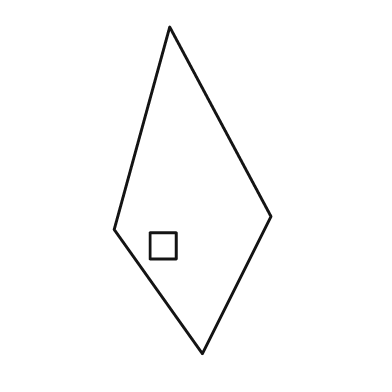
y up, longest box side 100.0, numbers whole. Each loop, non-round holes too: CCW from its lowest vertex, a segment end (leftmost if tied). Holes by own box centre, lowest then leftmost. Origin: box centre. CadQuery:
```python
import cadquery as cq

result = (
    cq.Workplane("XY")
    .moveTo(3.0, -50.0)
    .lineTo(24.0, -8.0)
    .lineTo(-7.0, 50.0)
    .lineTo(-24.0, -12.0)
    .close()
    .moveTo(-13.0, -21.0)
    .lineTo(-5.0, -21.0)
    .lineTo(-5.0, -13.0)
    .lineTo(-13.0, -13.0)
    .close()
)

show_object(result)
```